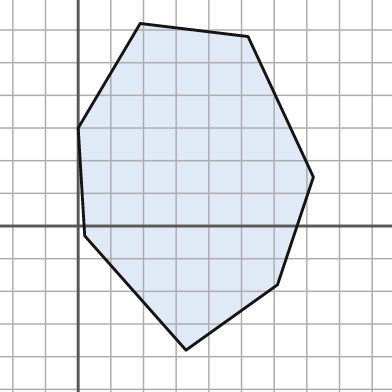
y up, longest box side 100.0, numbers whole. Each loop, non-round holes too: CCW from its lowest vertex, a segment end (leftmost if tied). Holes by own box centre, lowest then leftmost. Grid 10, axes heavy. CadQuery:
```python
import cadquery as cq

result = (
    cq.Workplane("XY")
    .moveTo(33.0, -38.0)
    .lineTo(61.0, -18.0)
    .lineTo(72.0, 15.0)
    .lineTo(52.0, 58.0)
    .lineTo(19.0, 62.0)
    .lineTo(0.0, 30.0)
    .lineTo(2.0, -3.0)
    .close()
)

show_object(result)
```